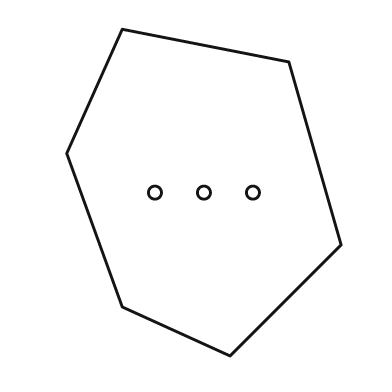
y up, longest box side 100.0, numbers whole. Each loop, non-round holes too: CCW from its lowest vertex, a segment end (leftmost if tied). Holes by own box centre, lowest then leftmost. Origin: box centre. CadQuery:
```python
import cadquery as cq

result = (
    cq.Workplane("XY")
    .moveTo(8.0, -50.0)
    .lineTo(42.0, -16.0)
    .lineTo(26.0, 40.0)
    .lineTo(-25.0, 50.0)
    .lineTo(-42.0, 12.0)
    .lineTo(-25.0, -35.0)
    .close()
    .moveTo(-15.0, 0.0)
    .circle(2.0)
    .moveTo(0.0, 0.0)
    .circle(2.0)
    .moveTo(15.0, 0.0)
    .circle(2.0)
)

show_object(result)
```